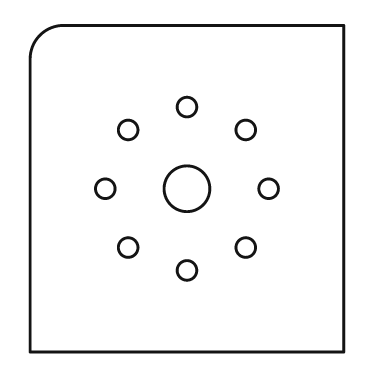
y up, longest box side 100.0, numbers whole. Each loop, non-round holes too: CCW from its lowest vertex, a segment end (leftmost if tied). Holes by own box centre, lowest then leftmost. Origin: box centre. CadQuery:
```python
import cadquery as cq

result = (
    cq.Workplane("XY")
    .moveTo(-48.0, -50.0)
    .lineTo(48.0, -50.0)
    .lineTo(48.0, 50.0)
    .lineTo(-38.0, 50.0)
    .threePointArc((-45.0, 47.0), (-48.0, 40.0))
    .close()
    .moveTo(0.0, -25.0)
    .circle(3.0)
    .moveTo(-18.0, -18.0)
    .circle(3.0)
    .moveTo(18.0, -18.0)
    .circle(3.0)
    .moveTo(-25.0, 0.0)
    .circle(3.0)
    .moveTo(0.0, 0.0)
    .circle(7.0)
    .moveTo(25.0, 0.0)
    .circle(3.0)
    .moveTo(-18.0, 18.0)
    .circle(3.0)
    .moveTo(18.0, 18.0)
    .circle(3.0)
    .moveTo(0.0, 25.0)
    .circle(3.0)
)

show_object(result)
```